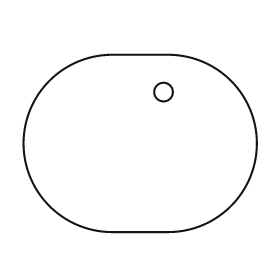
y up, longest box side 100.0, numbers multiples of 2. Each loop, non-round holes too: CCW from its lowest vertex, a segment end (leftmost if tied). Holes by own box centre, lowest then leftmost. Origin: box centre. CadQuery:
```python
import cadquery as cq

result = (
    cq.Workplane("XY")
    .moveTo(-12.0, -38.0)
    .lineTo(12.0, -38.0)
    .threePointArc((50.0, 0.0), (12.0, 38.0))
    .lineTo(-12.0, 38.0)
    .threePointArc((-50.0, 0.0), (-12.0, -38.0))
    .close()
    .moveTo(10.0, 22.0)
    .circle(4.0)
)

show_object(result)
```